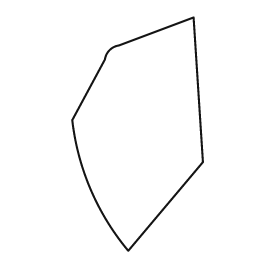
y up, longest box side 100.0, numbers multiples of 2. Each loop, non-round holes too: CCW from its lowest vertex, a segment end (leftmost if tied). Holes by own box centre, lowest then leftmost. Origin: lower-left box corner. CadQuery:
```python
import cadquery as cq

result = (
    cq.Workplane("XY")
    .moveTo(24.0, 0.0)
    .lineTo(56.0, 38.0)
    .lineTo(52.0, 100.0)
    .lineTo(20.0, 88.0)
    .threePointArc((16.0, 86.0), (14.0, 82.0))
    .lineTo(0.0, 56.0)
    .threePointArc((8.0, 26.0), (24.0, 0.0))
    .close()
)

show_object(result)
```